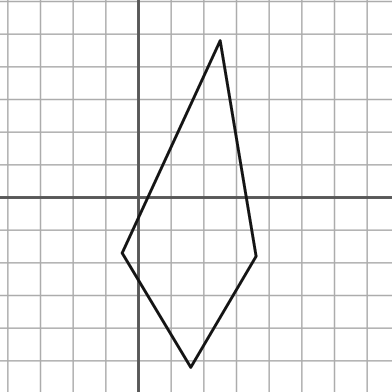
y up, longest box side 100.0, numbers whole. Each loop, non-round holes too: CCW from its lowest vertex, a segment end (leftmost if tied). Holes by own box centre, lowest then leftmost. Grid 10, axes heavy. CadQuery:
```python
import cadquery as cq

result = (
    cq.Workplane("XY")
    .moveTo(16.0, -52.0)
    .lineTo(36.0, -18.0)
    .lineTo(25.0, 48.0)
    .lineTo(-5.0, -17.0)
    .close()
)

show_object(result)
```